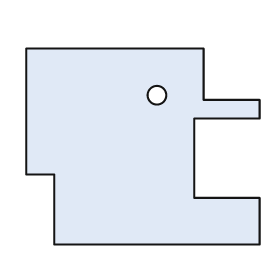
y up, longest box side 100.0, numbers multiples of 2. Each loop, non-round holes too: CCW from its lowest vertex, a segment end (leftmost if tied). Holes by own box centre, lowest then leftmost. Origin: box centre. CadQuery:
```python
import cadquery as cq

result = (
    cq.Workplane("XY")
    .moveTo(-38.0, -42.0)
    .lineTo(50.0, -42.0)
    .lineTo(50.0, -22.0)
    .lineTo(22.0, -22.0)
    .lineTo(22.0, 12.0)
    .lineTo(50.0, 12.0)
    .lineTo(50.0, 20.0)
    .lineTo(26.0, 20.0)
    .lineTo(26.0, 42.0)
    .lineTo(-50.0, 42.0)
    .lineTo(-50.0, -12.0)
    .lineTo(-38.0, -12.0)
    .close()
    .moveTo(6.0, 22.0)
    .circle(4.0)
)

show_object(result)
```